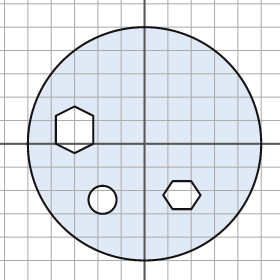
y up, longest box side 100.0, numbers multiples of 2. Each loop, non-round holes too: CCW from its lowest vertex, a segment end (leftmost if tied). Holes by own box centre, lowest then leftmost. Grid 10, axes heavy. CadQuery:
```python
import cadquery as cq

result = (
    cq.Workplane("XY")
    .moveTo(0.0, 0.0)
    .circle(50.0)
    .moveTo(-18.0, -24.0)
    .circle(6.0)
    .moveTo(12.0, -28.0)
    .lineTo(20.0, -28.0)
    .lineTo(24.0, -22.0)
    .lineTo(20.0, -16.0)
    .lineTo(12.0, -16.0)
    .lineTo(8.0, -22.0)
    .close()
    .moveTo(-30.0, -4.0)
    .lineTo(-22.0, 0.0)
    .lineTo(-22.0, 12.0)
    .lineTo(-30.0, 16.0)
    .lineTo(-38.0, 12.0)
    .lineTo(-38.0, 0.0)
    .close()
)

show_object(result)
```